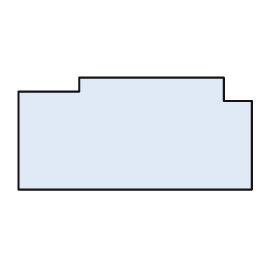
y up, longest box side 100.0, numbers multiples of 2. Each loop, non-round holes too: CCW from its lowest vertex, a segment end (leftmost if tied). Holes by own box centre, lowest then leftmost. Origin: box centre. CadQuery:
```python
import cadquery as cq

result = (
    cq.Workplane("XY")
    .moveTo(-50.0, -24.0)
    .lineTo(50.0, -24.0)
    .lineTo(50.0, 14.0)
    .lineTo(38.0, 14.0)
    .lineTo(38.0, 24.0)
    .lineTo(-24.0, 24.0)
    .lineTo(-24.0, 18.0)
    .lineTo(-50.0, 18.0)
    .close()
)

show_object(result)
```